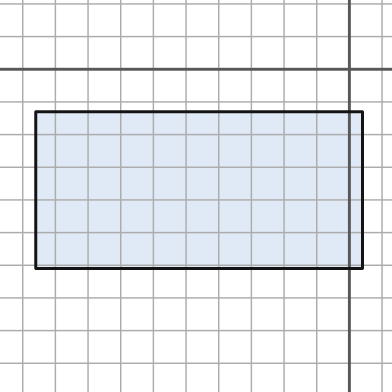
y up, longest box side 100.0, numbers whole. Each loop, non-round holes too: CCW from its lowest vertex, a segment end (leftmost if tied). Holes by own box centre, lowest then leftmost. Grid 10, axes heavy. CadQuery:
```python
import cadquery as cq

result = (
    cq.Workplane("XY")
    .moveTo(-96.0, -61.0)
    .lineTo(4.0, -61.0)
    .lineTo(4.0, -13.0)
    .lineTo(-96.0, -13.0)
    .close()
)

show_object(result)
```